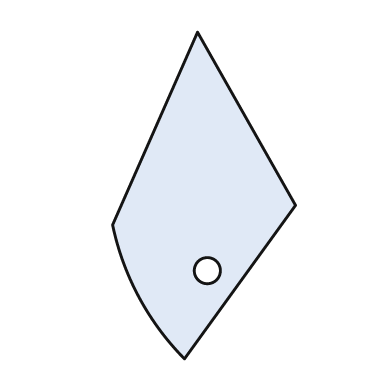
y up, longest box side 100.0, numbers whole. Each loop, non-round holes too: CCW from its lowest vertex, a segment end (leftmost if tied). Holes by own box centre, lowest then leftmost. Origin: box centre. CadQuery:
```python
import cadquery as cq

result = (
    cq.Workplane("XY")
    .moveTo(-6.0, -50.0)
    .lineTo(28.0, -3.0)
    .lineTo(-2.0, 50.0)
    .lineTo(-28.0, -9.0)
    .threePointArc((-20.0, -31.0), (-6.0, -50.0))
    .close()
    .moveTo(1.0, -23.0)
    .circle(4.0)
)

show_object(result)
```